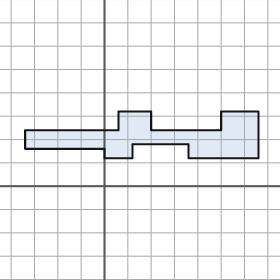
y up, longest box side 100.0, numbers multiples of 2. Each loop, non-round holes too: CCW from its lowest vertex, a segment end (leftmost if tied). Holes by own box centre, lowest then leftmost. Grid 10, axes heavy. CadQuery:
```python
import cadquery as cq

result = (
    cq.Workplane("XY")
    .moveTo(0.0, 12.0)
    .lineTo(12.0, 12.0)
    .lineTo(12.0, 18.0)
    .lineTo(36.0, 18.0)
    .lineTo(36.0, 12.0)
    .lineTo(66.0, 12.0)
    .lineTo(66.0, 32.0)
    .lineTo(50.0, 32.0)
    .lineTo(50.0, 24.0)
    .lineTo(20.0, 24.0)
    .lineTo(20.0, 32.0)
    .lineTo(6.0, 32.0)
    .lineTo(6.0, 24.0)
    .lineTo(-34.0, 24.0)
    .lineTo(-34.0, 16.0)
    .lineTo(0.0, 16.0)
    .close()
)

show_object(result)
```